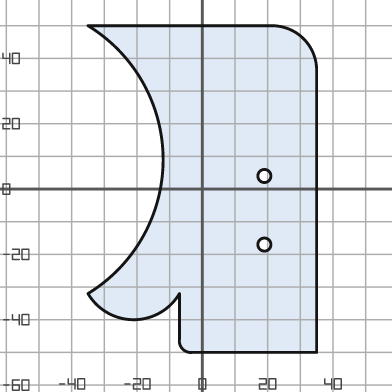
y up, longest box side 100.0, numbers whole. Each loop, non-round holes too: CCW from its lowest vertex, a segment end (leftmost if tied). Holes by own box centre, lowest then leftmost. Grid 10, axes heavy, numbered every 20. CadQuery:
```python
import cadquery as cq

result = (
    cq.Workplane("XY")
    .moveTo(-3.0, -50.0)
    .lineTo(35.0, -50.0)
    .lineTo(35.0, 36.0)
    .threePointArc((31.0, 46.0), (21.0, 50.0))
    .lineTo(-35.0, 50.0)
    .threePointArc((-12.0, 9.0), (-35.0, -32.0))
    .threePointArc((-21.0, -40.0), (-7.0, -32.0))
    .lineTo(-7.0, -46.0)
    .threePointArc((-6.0, -49.0), (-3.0, -50.0))
    .close()
    .moveTo(19.0, -17.0)
    .circle(2.0)
    .moveTo(19.0, 4.0)
    .circle(2.0)
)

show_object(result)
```